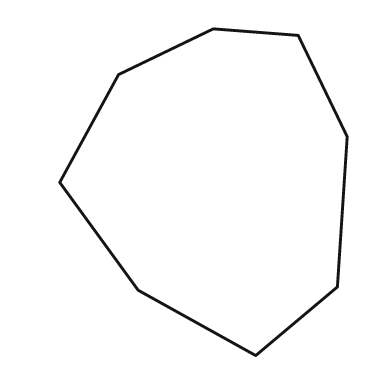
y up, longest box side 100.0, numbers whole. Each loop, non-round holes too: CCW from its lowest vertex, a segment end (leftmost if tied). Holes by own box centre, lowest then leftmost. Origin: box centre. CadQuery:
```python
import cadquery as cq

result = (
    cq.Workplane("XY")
    .moveTo(16.0, -50.0)
    .lineTo(41.0, -29.0)
    .lineTo(44.0, 17.0)
    .lineTo(29.0, 48.0)
    .lineTo(3.0, 50.0)
    .lineTo(-26.0, 36.0)
    .lineTo(-44.0, 3.0)
    .lineTo(-20.0, -30.0)
    .close()
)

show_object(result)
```